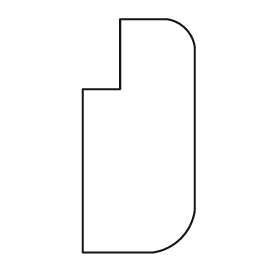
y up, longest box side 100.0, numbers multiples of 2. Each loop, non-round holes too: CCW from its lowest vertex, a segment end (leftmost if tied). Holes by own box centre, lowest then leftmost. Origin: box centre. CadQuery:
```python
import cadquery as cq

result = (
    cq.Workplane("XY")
    .moveTo(-24.0, -50.0)
    .lineTo(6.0, -50.0)
    .threePointArc((18.0, -44.0), (24.0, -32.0))
    .lineTo(24.0, 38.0)
    .threePointArc((20.0, 46.0), (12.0, 50.0))
    .lineTo(-8.0, 50.0)
    .lineTo(-8.0, 20.0)
    .lineTo(-24.0, 20.0)
    .close()
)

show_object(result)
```